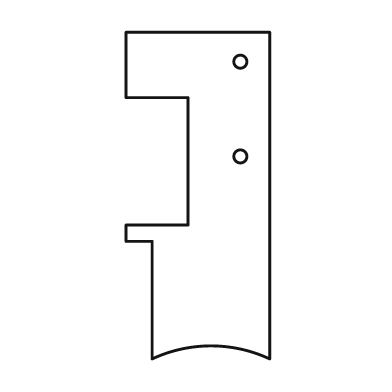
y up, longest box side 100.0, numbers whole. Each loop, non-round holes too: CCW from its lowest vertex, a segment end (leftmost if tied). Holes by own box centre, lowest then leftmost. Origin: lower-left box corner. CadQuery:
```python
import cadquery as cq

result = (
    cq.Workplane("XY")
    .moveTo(8.0, 0.0)
    .threePointArc((26.0, 4.0), (44.0, 0.0))
    .lineTo(44.0, 100.0)
    .lineTo(0.0, 100.0)
    .lineTo(0.0, 80.0)
    .lineTo(19.0, 80.0)
    .lineTo(19.0, 41.0)
    .lineTo(0.0, 41.0)
    .lineTo(0.0, 36.0)
    .lineTo(8.0, 36.0)
    .close()
    .moveTo(35.0, 62.0)
    .circle(2.0)
    .moveTo(35.0, 91.0)
    .circle(2.0)
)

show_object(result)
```